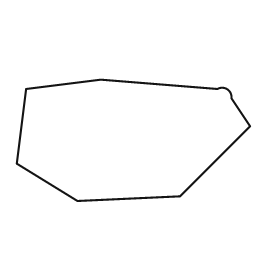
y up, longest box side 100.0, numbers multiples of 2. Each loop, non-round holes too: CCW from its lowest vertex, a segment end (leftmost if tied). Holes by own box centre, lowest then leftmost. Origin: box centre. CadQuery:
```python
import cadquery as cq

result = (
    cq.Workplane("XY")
    .moveTo(-24.0, -26.0)
    .lineTo(20.0, -24.0)
    .lineTo(50.0, 6.0)
    .lineTo(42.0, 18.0)
    .threePointArc((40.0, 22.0), (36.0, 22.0))
    .lineTo(-14.0, 26.0)
    .lineTo(-46.0, 22.0)
    .lineTo(-50.0, -10.0)
    .close()
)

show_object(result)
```